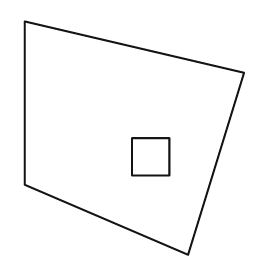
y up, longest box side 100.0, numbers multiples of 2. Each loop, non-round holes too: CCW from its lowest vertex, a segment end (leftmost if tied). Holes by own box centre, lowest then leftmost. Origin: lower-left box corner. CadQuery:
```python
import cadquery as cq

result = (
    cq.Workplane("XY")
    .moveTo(70.0, 0.0)
    .lineTo(94.0, 78.0)
    .lineTo(0.0, 100.0)
    .lineTo(0.0, 30.0)
    .close()
    .moveTo(46.0, 34.0)
    .lineTo(62.0, 34.0)
    .lineTo(62.0, 50.0)
    .lineTo(46.0, 50.0)
    .close()
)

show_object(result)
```